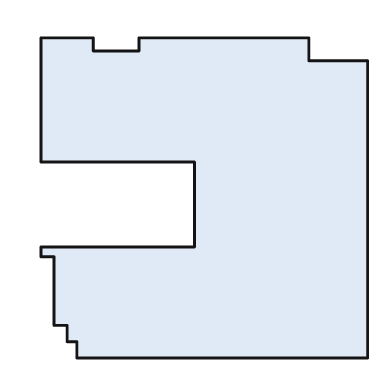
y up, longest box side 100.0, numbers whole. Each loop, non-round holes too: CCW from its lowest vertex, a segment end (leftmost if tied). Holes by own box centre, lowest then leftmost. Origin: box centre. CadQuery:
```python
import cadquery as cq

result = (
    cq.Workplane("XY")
    .moveTo(-39.0, -49.0)
    .lineTo(50.0, -49.0)
    .lineTo(50.0, 42.0)
    .lineTo(32.0, 42.0)
    .lineTo(32.0, 49.0)
    .lineTo(-20.0, 49.0)
    .lineTo(-20.0, 45.0)
    .lineTo(-34.0, 45.0)
    .lineTo(-34.0, 49.0)
    .lineTo(-50.0, 49.0)
    .lineTo(-50.0, 11.0)
    .lineTo(-3.0, 11.0)
    .lineTo(-3.0, -15.0)
    .lineTo(-50.0, -15.0)
    .lineTo(-50.0, -18.0)
    .lineTo(-46.0, -18.0)
    .lineTo(-46.0, -39.0)
    .lineTo(-42.0, -39.0)
    .lineTo(-42.0, -44.0)
    .lineTo(-39.0, -44.0)
    .close()
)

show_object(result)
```